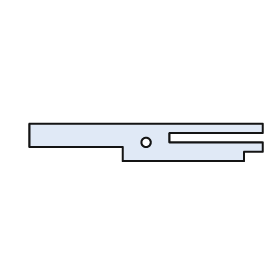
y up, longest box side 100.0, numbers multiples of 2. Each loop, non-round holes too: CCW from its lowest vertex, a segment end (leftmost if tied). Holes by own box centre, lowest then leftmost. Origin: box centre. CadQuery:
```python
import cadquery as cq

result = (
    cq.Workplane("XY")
    .moveTo(-10.0, -8.0)
    .lineTo(42.0, -8.0)
    .lineTo(42.0, -4.0)
    .lineTo(50.0, -4.0)
    .lineTo(50.0, 0.0)
    .lineTo(10.0, 0.0)
    .lineTo(10.0, 4.0)
    .lineTo(50.0, 4.0)
    .lineTo(50.0, 8.0)
    .lineTo(-50.0, 8.0)
    .lineTo(-50.0, -2.0)
    .lineTo(-10.0, -2.0)
    .close()
    .moveTo(0.0, 0.0)
    .circle(2.0)
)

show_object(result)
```